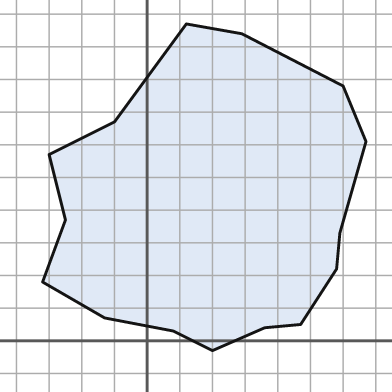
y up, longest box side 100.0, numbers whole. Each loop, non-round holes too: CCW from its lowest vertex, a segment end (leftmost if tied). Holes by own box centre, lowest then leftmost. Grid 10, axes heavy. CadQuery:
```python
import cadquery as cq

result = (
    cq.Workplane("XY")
    .moveTo(20.0, -3.0)
    .lineTo(36.0, 4.0)
    .lineTo(47.0, 5.0)
    .lineTo(58.0, 22.0)
    .lineTo(59.0, 33.0)
    .lineTo(67.0, 61.0)
    .lineTo(60.0, 78.0)
    .lineTo(29.0, 94.0)
    .lineTo(12.0, 97.0)
    .lineTo(-10.0, 67.0)
    .lineTo(-30.0, 57.0)
    .lineTo(-25.0, 37.0)
    .lineTo(-32.0, 18.0)
    .lineTo(-13.0, 7.0)
    .lineTo(8.0, 3.0)
    .close()
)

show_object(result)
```